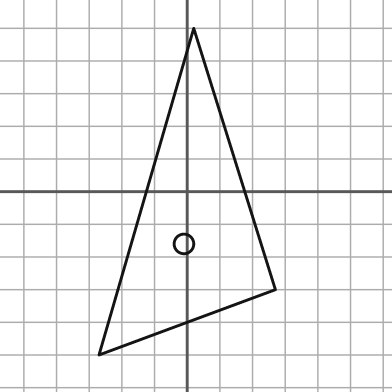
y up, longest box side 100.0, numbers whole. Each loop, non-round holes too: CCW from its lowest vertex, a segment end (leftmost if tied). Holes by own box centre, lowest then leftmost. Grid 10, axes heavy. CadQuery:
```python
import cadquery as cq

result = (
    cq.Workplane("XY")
    .moveTo(-27.0, -50.0)
    .lineTo(27.0, -30.0)
    .lineTo(2.0, 50.0)
    .close()
    .moveTo(-1.0, -16.0)
    .circle(3.0)
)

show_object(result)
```